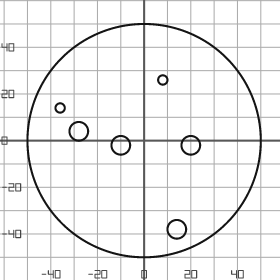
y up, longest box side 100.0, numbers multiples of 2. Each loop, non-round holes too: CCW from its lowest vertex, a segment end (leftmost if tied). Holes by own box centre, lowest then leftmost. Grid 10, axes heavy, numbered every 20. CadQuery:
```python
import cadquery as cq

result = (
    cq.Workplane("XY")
    .moveTo(0.0, 0.0)
    .circle(50.0)
    .moveTo(14.0, -38.0)
    .circle(4.0)
    .moveTo(-10.0, -2.0)
    .circle(4.0)
    .moveTo(20.0, -2.0)
    .circle(4.0)
    .moveTo(-28.0, 4.0)
    .circle(4.0)
    .moveTo(-36.0, 14.0)
    .circle(2.0)
    .moveTo(8.0, 26.0)
    .circle(2.0)
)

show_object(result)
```